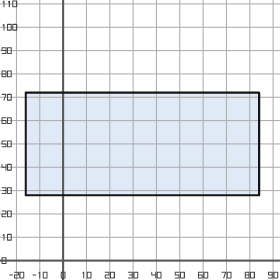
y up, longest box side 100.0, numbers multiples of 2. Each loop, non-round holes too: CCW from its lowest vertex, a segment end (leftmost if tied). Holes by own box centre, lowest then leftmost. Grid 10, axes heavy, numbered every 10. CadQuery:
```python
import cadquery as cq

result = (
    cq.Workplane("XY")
    .moveTo(-16.0, 28.0)
    .lineTo(84.0, 28.0)
    .lineTo(84.0, 72.0)
    .lineTo(-16.0, 72.0)
    .close()
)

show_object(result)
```